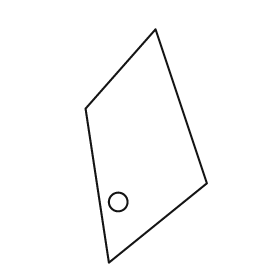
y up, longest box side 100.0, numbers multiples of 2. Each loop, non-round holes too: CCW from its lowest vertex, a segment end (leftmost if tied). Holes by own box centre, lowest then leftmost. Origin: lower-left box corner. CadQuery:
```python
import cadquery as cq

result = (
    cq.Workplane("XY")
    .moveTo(10.0, 0.0)
    .lineTo(52.0, 34.0)
    .lineTo(30.0, 100.0)
    .lineTo(0.0, 66.0)
    .close()
    .moveTo(14.0, 26.0)
    .circle(4.0)
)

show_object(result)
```